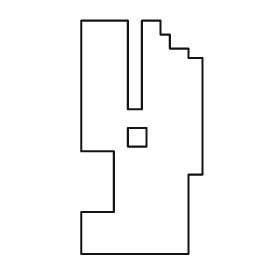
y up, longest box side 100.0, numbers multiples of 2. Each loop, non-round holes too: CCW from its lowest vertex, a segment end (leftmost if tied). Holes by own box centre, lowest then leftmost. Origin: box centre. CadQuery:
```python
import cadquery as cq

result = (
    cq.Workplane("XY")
    .moveTo(-26.0, -50.0)
    .lineTo(20.0, -50.0)
    .lineTo(20.0, -16.0)
    .lineTo(26.0, -16.0)
    .lineTo(26.0, 34.0)
    .lineTo(20.0, 34.0)
    .lineTo(20.0, 38.0)
    .lineTo(12.0, 38.0)
    .lineTo(12.0, 44.0)
    .lineTo(8.0, 44.0)
    .lineTo(8.0, 50.0)
    .lineTo(0.0, 50.0)
    .lineTo(0.0, 12.0)
    .lineTo(-6.0, 12.0)
    .lineTo(-6.0, 50.0)
    .lineTo(-26.0, 50.0)
    .lineTo(-26.0, -6.0)
    .lineTo(-12.0, -6.0)
    .lineTo(-12.0, -32.0)
    .lineTo(-26.0, -32.0)
    .close()
    .moveTo(-6.0, -4.0)
    .lineTo(2.0, -4.0)
    .lineTo(2.0, 4.0)
    .lineTo(-6.0, 4.0)
    .close()
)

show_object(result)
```